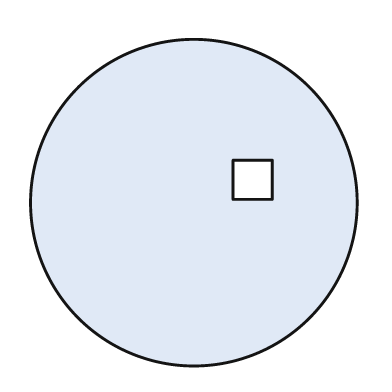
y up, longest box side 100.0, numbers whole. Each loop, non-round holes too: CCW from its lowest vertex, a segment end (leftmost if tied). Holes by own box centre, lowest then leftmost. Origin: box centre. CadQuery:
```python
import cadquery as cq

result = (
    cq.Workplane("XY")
    .moveTo(0.0, 0.0)
    .circle(50.0)
    .moveTo(12.0, 1.0)
    .lineTo(24.0, 1.0)
    .lineTo(24.0, 13.0)
    .lineTo(12.0, 13.0)
    .close()
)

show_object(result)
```